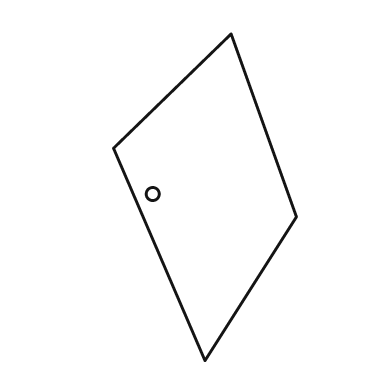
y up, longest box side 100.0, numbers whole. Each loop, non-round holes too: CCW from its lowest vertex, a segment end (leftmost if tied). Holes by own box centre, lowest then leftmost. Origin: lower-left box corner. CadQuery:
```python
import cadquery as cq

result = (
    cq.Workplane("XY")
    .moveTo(28.0, 0.0)
    .lineTo(56.0, 44.0)
    .lineTo(36.0, 100.0)
    .lineTo(0.0, 65.0)
    .close()
    .moveTo(12.0, 51.0)
    .circle(2.0)
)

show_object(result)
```